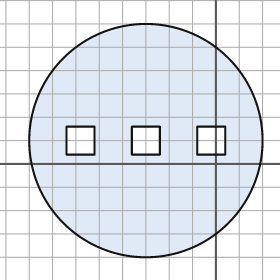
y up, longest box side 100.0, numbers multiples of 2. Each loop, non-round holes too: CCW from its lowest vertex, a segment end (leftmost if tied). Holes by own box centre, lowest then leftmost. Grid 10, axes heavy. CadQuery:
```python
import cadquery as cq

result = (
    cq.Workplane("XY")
    .moveTo(-30.0, 10.0)
    .circle(50.0)
    .moveTo(-64.0, 4.0)
    .lineTo(-52.0, 4.0)
    .lineTo(-52.0, 16.0)
    .lineTo(-64.0, 16.0)
    .close()
    .moveTo(-36.0, 4.0)
    .lineTo(-24.0, 4.0)
    .lineTo(-24.0, 16.0)
    .lineTo(-36.0, 16.0)
    .close()
    .moveTo(-8.0, 4.0)
    .lineTo(4.0, 4.0)
    .lineTo(4.0, 16.0)
    .lineTo(-8.0, 16.0)
    .close()
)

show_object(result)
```